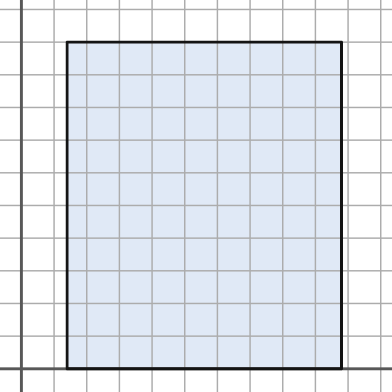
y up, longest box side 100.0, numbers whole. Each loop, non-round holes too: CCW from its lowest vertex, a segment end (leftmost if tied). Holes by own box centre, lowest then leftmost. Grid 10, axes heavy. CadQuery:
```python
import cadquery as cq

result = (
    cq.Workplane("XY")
    .moveTo(14.0, 0.0)
    .lineTo(98.0, 0.0)
    .lineTo(98.0, 100.0)
    .lineTo(14.0, 100.0)
    .close()
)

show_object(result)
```